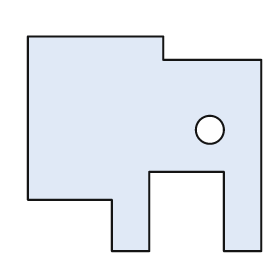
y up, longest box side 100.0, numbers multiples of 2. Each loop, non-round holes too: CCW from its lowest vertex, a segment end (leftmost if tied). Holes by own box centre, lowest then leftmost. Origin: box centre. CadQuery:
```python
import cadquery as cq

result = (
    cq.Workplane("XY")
    .moveTo(-14.0, -46.0)
    .lineTo(2.0, -46.0)
    .lineTo(2.0, -12.0)
    .lineTo(34.0, -12.0)
    .lineTo(34.0, -46.0)
    .lineTo(50.0, -46.0)
    .lineTo(50.0, 36.0)
    .lineTo(8.0, 36.0)
    .lineTo(8.0, 46.0)
    .lineTo(-50.0, 46.0)
    .lineTo(-50.0, -24.0)
    .lineTo(-14.0, -24.0)
    .close()
    .moveTo(28.0, 6.0)
    .circle(6.0)
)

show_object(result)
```